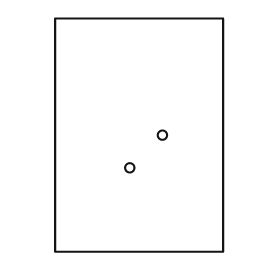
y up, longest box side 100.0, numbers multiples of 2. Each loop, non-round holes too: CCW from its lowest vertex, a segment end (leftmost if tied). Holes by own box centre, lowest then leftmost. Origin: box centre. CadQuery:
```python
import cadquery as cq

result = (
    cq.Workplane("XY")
    .moveTo(-36.0, -50.0)
    .lineTo(36.0, -50.0)
    .lineTo(36.0, 50.0)
    .lineTo(-36.0, 50.0)
    .close()
    .moveTo(-4.0, -14.0)
    .circle(2.0)
    .moveTo(10.0, 0.0)
    .circle(2.0)
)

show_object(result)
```